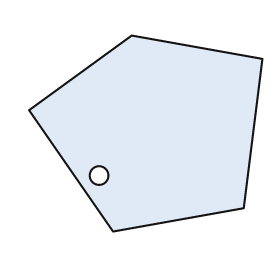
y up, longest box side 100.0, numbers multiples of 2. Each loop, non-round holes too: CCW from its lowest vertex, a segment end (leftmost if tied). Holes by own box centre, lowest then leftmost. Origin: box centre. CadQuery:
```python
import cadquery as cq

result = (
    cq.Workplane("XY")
    .moveTo(-14.0, -42.0)
    .lineTo(42.0, -32.0)
    .lineTo(50.0, 32.0)
    .lineTo(-6.0, 42.0)
    .lineTo(-50.0, 10.0)
    .close()
    .moveTo(-20.0, -18.0)
    .circle(4.0)
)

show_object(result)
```